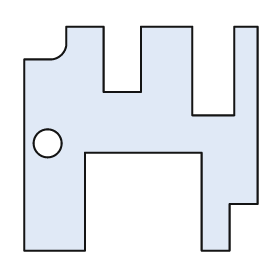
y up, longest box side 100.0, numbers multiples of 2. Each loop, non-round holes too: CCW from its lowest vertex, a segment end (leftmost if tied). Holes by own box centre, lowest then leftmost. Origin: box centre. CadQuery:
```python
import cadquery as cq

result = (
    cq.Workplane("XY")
    .moveTo(-50.0, -48.0)
    .lineTo(-24.0, -48.0)
    .lineTo(-24.0, -6.0)
    .lineTo(26.0, -6.0)
    .lineTo(26.0, -48.0)
    .lineTo(38.0, -48.0)
    .lineTo(38.0, -28.0)
    .lineTo(50.0, -28.0)
    .lineTo(50.0, 48.0)
    .lineTo(40.0, 48.0)
    .lineTo(40.0, 10.0)
    .lineTo(22.0, 10.0)
    .lineTo(22.0, 48.0)
    .lineTo(0.0, 48.0)
    .lineTo(0.0, 20.0)
    .lineTo(-16.0, 20.0)
    .lineTo(-16.0, 48.0)
    .lineTo(-32.0, 48.0)
    .lineTo(-32.0, 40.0)
    .threePointArc((-34.0, 36.0), (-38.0, 34.0))
    .lineTo(-50.0, 34.0)
    .close()
    .moveTo(-40.0, -2.0)
    .circle(6.0)
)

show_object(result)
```